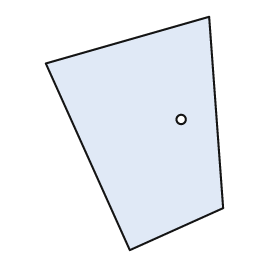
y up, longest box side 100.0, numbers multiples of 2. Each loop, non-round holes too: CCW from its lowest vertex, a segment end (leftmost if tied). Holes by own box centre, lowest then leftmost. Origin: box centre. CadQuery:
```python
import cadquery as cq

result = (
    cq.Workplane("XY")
    .moveTo(-2.0, -50.0)
    .lineTo(38.0, -32.0)
    .lineTo(32.0, 50.0)
    .lineTo(-38.0, 30.0)
    .close()
    .moveTo(20.0, 6.0)
    .circle(2.0)
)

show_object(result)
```